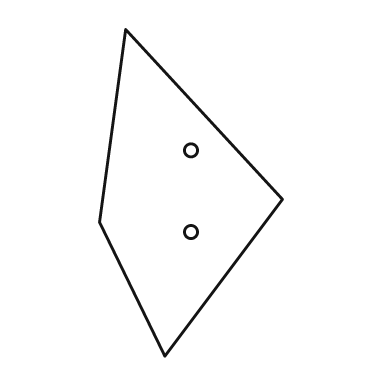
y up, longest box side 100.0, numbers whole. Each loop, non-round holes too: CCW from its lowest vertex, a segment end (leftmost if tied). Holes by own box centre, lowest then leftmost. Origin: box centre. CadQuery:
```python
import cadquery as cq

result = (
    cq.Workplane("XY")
    .moveTo(-8.0, -50.0)
    .lineTo(28.0, -2.0)
    .lineTo(-20.0, 50.0)
    .lineTo(-28.0, -9.0)
    .close()
    .moveTo(0.0, -12.0)
    .circle(2.0)
    .moveTo(0.0, 13.0)
    .circle(2.0)
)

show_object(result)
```